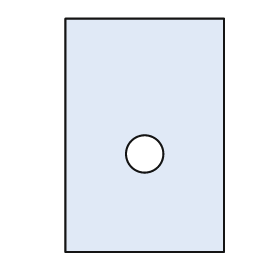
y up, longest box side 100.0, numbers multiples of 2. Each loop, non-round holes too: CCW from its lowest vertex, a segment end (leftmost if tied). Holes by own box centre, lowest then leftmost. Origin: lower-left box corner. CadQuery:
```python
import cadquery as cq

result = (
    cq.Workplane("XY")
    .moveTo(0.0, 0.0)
    .lineTo(68.0, 0.0)
    .lineTo(68.0, 100.0)
    .lineTo(0.0, 100.0)
    .close()
    .moveTo(34.0, 42.0)
    .circle(8.0)
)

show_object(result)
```